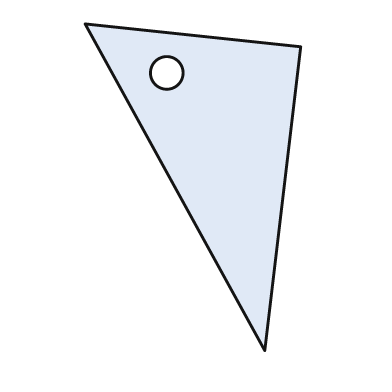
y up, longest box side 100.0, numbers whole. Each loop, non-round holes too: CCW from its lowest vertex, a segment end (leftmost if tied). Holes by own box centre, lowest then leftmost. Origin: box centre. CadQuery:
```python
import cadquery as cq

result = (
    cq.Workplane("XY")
    .moveTo(22.0, -50.0)
    .lineTo(33.0, 43.0)
    .lineTo(-33.0, 50.0)
    .close()
    .moveTo(-8.0, 35.0)
    .circle(5.0)
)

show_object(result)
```